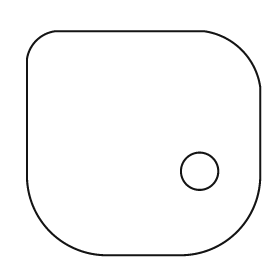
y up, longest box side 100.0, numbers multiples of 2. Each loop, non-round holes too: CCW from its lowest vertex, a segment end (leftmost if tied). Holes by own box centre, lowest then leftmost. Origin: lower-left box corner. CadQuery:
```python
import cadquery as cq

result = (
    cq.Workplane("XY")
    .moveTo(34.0, 0.0)
    .lineTo(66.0, 0.0)
    .threePointArc((90.0, 10.0), (100.0, 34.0))
    .lineTo(100.0, 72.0)
    .threePointArc((92.0, 88.0), (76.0, 96.0))
    .lineTo(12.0, 96.0)
    .threePointArc((4.0, 92.0), (0.0, 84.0))
    .lineTo(0.0, 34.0)
    .threePointArc((10.0, 10.0), (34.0, 0.0))
    .close()
    .moveTo(74.0, 36.0)
    .circle(8.0)
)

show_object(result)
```